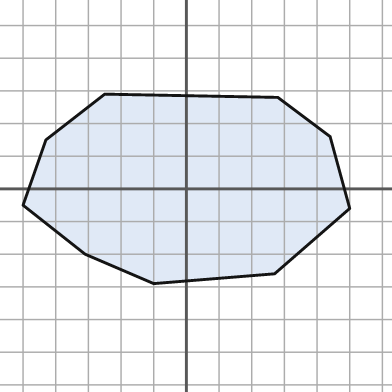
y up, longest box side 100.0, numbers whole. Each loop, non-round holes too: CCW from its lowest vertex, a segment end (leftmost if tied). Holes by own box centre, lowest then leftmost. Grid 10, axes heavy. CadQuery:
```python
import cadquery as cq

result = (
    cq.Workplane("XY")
    .moveTo(-10.0, -29.0)
    .lineTo(27.0, -26.0)
    .lineTo(50.0, -6.0)
    .lineTo(44.0, 16.0)
    .lineTo(28.0, 28.0)
    .lineTo(-25.0, 29.0)
    .lineTo(-43.0, 15.0)
    .lineTo(-50.0, -5.0)
    .lineTo(-31.0, -20.0)
    .close()
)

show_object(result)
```